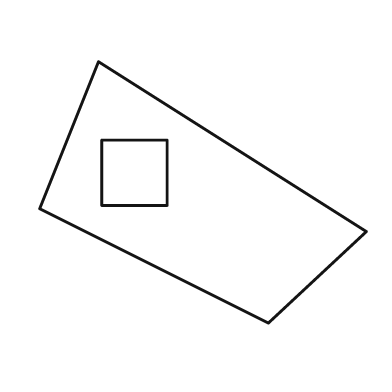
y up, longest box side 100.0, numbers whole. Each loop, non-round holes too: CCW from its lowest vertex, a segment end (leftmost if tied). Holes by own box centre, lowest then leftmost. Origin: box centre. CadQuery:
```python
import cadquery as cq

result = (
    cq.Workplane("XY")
    .moveTo(20.0, -40.0)
    .lineTo(50.0, -12.0)
    .lineTo(-32.0, 40.0)
    .lineTo(-50.0, -5.0)
    .close()
    .moveTo(-31.0, -4.0)
    .lineTo(-11.0, -4.0)
    .lineTo(-11.0, 16.0)
    .lineTo(-31.0, 16.0)
    .close()
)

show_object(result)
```